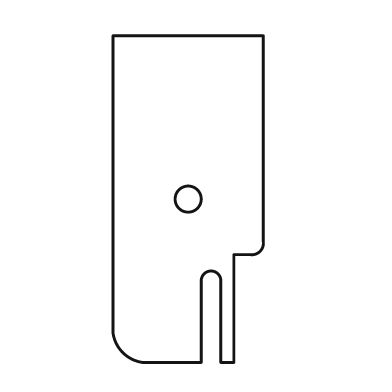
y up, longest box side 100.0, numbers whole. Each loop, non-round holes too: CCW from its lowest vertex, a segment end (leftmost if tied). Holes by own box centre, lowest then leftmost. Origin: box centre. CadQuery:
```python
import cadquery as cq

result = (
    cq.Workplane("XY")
    .moveTo(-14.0, -50.0)
    .lineTo(4.0, -50.0)
    .lineTo(4.0, -25.0)
    .threePointArc((7.0, -22.0), (10.0, -25.0))
    .lineTo(10.0, -50.0)
    .lineTo(14.0, -50.0)
    .lineTo(14.0, -17.0)
    .lineTo(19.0, -17.0)
    .threePointArc((22.0, -16.0), (23.0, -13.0))
    .lineTo(23.0, 50.0)
    .lineTo(-23.0, 50.0)
    .lineTo(-23.0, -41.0)
    .threePointArc((-20.0, -47.0), (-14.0, -50.0))
    .close()
    .moveTo(0.0, 0.0)
    .circle(4.0)
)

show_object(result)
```